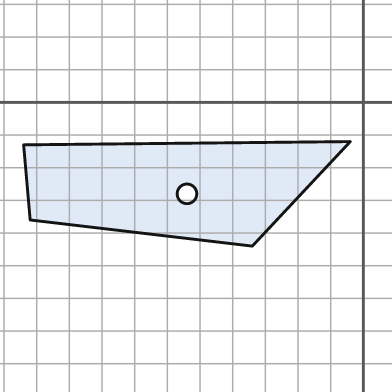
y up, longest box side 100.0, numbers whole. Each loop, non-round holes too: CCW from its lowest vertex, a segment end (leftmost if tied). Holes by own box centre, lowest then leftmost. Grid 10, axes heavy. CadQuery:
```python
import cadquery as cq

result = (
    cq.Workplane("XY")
    .moveTo(-34.0, -44.0)
    .lineTo(-4.0, -12.0)
    .lineTo(-104.0, -13.0)
    .lineTo(-102.0, -36.0)
    .close()
    .moveTo(-54.0, -28.0)
    .circle(3.0)
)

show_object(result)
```